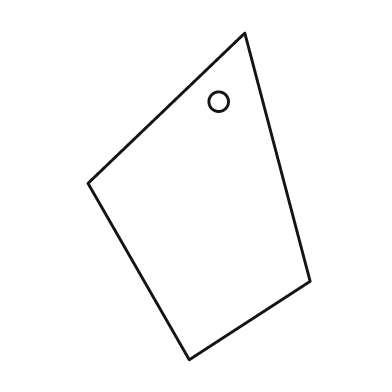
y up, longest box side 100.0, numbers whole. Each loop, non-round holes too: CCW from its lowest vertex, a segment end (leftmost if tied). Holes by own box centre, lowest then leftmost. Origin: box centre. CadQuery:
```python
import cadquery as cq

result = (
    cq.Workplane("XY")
    .moveTo(-3.0, -50.0)
    .lineTo(34.0, -26.0)
    .lineTo(14.0, 50.0)
    .lineTo(-34.0, 4.0)
    .close()
    .moveTo(6.0, 29.0)
    .circle(3.0)
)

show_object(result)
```